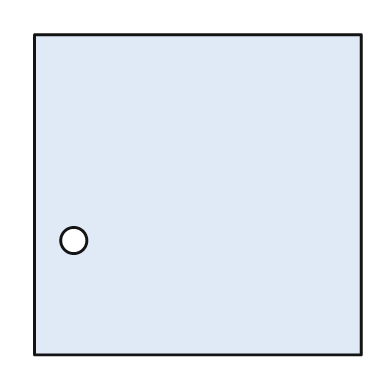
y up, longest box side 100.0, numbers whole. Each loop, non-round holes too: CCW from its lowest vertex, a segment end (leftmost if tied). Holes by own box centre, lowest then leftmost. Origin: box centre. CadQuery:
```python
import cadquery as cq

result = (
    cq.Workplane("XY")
    .moveTo(-50.0, -49.0)
    .lineTo(50.0, -49.0)
    .lineTo(50.0, 49.0)
    .lineTo(-50.0, 49.0)
    .close()
    .moveTo(-38.0, -14.0)
    .circle(4.0)
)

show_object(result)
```